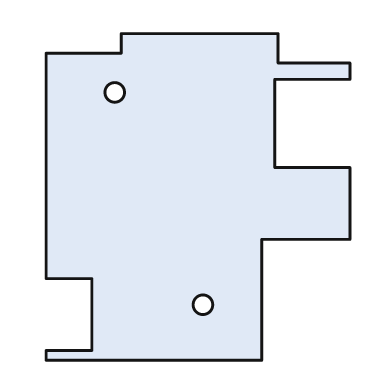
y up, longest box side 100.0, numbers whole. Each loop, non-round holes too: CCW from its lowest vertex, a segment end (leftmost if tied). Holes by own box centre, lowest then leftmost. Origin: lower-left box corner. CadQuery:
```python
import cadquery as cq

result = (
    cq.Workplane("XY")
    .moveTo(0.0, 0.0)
    .lineTo(66.0, 0.0)
    .lineTo(66.0, 37.0)
    .lineTo(93.0, 37.0)
    .lineTo(93.0, 59.0)
    .lineTo(70.0, 59.0)
    .lineTo(70.0, 86.0)
    .lineTo(93.0, 86.0)
    .lineTo(93.0, 91.0)
    .lineTo(71.0, 91.0)
    .lineTo(71.0, 100.0)
    .lineTo(23.0, 100.0)
    .lineTo(23.0, 94.0)
    .lineTo(0.0, 94.0)
    .lineTo(0.0, 25.0)
    .lineTo(14.0, 25.0)
    .lineTo(14.0, 3.0)
    .lineTo(0.0, 3.0)
    .close()
    .moveTo(48.0, 17.0)
    .circle(3.0)
    .moveTo(21.0, 82.0)
    .circle(3.0)
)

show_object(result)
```